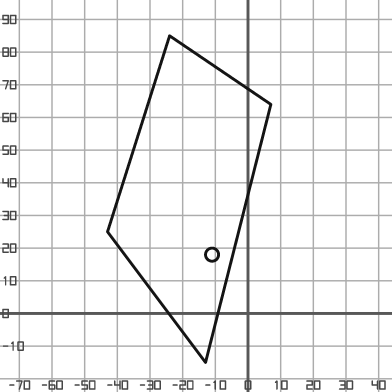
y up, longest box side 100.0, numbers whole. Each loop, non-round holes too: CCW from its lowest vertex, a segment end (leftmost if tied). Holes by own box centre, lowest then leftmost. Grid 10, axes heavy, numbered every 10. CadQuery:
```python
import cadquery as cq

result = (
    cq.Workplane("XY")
    .moveTo(-13.0, -15.0)
    .lineTo(7.0, 64.0)
    .lineTo(-24.0, 85.0)
    .lineTo(-43.0, 25.0)
    .close()
    .moveTo(-11.0, 18.0)
    .circle(2.0)
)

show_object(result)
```